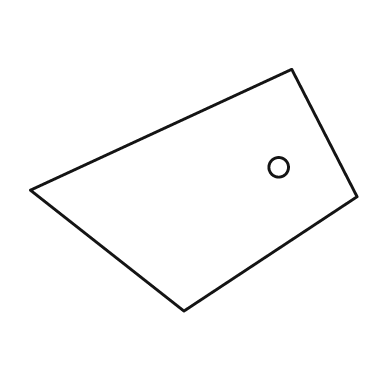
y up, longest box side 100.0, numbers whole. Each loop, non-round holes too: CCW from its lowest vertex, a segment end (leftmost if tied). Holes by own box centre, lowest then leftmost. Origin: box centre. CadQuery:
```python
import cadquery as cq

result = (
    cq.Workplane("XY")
    .moveTo(-3.0, -37.0)
    .lineTo(50.0, -2.0)
    .lineTo(30.0, 37.0)
    .lineTo(-50.0, 0.0)
    .close()
    .moveTo(26.0, 7.0)
    .circle(3.0)
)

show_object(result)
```